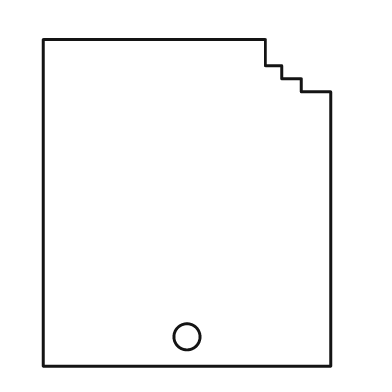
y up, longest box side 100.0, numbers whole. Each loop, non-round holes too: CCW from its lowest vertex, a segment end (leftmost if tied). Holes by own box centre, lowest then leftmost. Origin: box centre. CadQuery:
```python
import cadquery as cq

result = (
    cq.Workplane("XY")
    .moveTo(-44.0, -50.0)
    .lineTo(44.0, -50.0)
    .lineTo(44.0, 34.0)
    .lineTo(35.0, 34.0)
    .lineTo(35.0, 38.0)
    .lineTo(29.0, 38.0)
    .lineTo(29.0, 42.0)
    .lineTo(24.0, 42.0)
    .lineTo(24.0, 50.0)
    .lineTo(-44.0, 50.0)
    .close()
    .moveTo(0.0, -41.0)
    .circle(4.0)
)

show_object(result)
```